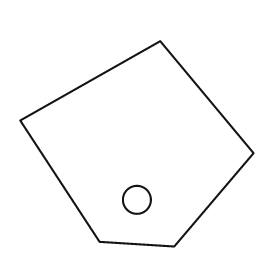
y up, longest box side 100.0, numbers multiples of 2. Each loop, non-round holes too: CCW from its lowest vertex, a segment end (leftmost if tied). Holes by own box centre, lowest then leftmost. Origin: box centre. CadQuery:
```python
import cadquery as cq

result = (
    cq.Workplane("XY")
    .moveTo(16.0, -44.0)
    .lineTo(50.0, -4.0)
    .lineTo(10.0, 44.0)
    .lineTo(-50.0, 10.0)
    .lineTo(-16.0, -42.0)
    .close()
    .moveTo(0.0, -24.0)
    .circle(6.0)
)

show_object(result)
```